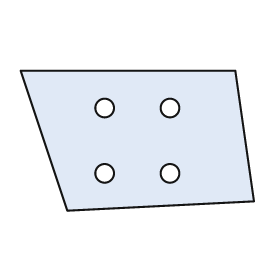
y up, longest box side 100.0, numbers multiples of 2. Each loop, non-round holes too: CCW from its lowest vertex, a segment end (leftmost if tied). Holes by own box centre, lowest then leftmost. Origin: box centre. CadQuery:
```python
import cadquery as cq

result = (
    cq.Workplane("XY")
    .moveTo(-30.0, -30.0)
    .lineTo(50.0, -26.0)
    .lineTo(42.0, 30.0)
    .lineTo(-50.0, 30.0)
    .close()
    .moveTo(-14.0, -14.0)
    .circle(4.0)
    .moveTo(14.0, -14.0)
    .circle(4.0)
    .moveTo(-14.0, 14.0)
    .circle(4.0)
    .moveTo(14.0, 14.0)
    .circle(4.0)
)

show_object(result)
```